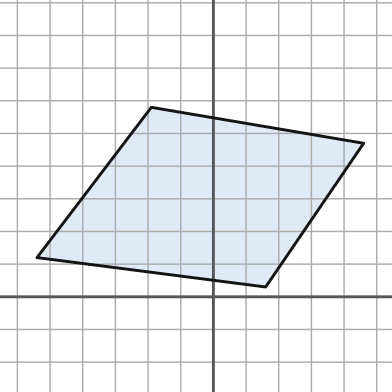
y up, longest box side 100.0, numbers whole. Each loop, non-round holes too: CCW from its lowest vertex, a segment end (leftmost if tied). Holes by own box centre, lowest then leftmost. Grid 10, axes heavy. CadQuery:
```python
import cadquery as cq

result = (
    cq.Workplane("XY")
    .moveTo(16.0, 3.0)
    .lineTo(46.0, 47.0)
    .lineTo(-19.0, 58.0)
    .lineTo(-54.0, 12.0)
    .close()
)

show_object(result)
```